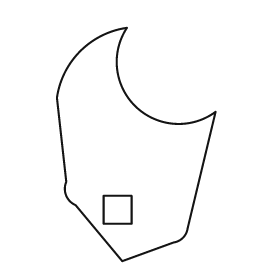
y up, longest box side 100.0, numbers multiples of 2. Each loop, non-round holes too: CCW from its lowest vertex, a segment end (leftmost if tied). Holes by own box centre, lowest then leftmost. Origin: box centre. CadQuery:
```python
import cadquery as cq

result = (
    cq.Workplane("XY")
    .moveTo(-6.0, -50.0)
    .lineTo(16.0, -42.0)
    .threePointArc((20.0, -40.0), (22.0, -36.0))
    .lineTo(34.0, 14.0)
    .threePointArc((0.0, 16.0), (-4.0, 50.0))
    .threePointArc((-24.0, 40.0), (-34.0, 20.0))
    .lineTo(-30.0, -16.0)
    .threePointArc((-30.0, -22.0), (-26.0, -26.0))
    .close()
    .moveTo(-14.0, -34.0)
    .lineTo(-2.0, -34.0)
    .lineTo(-2.0, -22.0)
    .lineTo(-14.0, -22.0)
    .close()
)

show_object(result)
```